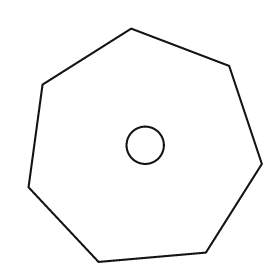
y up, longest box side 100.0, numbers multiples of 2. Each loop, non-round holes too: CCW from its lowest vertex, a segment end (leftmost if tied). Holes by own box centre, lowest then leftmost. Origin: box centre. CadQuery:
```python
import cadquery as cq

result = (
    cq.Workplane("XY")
    .moveTo(-20.0, -50.0)
    .lineTo(26.0, -46.0)
    .lineTo(50.0, -8.0)
    .lineTo(36.0, 34.0)
    .lineTo(-6.0, 50.0)
    .lineTo(-44.0, 26.0)
    .lineTo(-50.0, -18.0)
    .close()
    .moveTo(0.0, 0.0)
    .circle(8.0)
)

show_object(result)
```